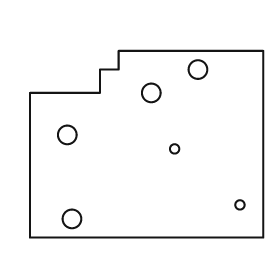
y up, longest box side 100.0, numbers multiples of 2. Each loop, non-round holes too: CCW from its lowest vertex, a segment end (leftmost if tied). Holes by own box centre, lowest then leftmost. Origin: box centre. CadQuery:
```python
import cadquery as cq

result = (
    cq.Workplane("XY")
    .moveTo(-50.0, -40.0)
    .lineTo(50.0, -40.0)
    .lineTo(50.0, 40.0)
    .lineTo(-12.0, 40.0)
    .lineTo(-12.0, 32.0)
    .lineTo(-20.0, 32.0)
    .lineTo(-20.0, 22.0)
    .lineTo(-50.0, 22.0)
    .close()
    .moveTo(-32.0, -32.0)
    .circle(4.0)
    .moveTo(40.0, -26.0)
    .circle(2.0)
    .moveTo(12.0, -2.0)
    .circle(2.0)
    .moveTo(-34.0, 4.0)
    .circle(4.0)
    .moveTo(2.0, 22.0)
    .circle(4.0)
    .moveTo(22.0, 32.0)
    .circle(4.0)
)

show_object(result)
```